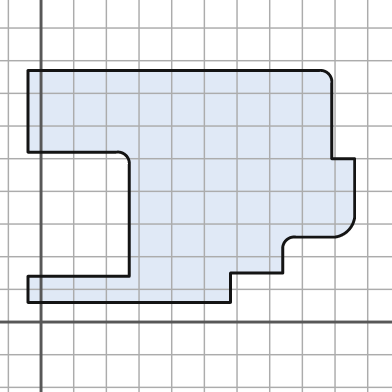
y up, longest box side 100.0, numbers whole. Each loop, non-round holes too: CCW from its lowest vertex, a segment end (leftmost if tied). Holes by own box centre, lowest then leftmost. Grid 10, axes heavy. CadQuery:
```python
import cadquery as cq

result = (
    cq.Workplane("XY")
    .moveTo(-4.0, 6.0)
    .lineTo(58.0, 6.0)
    .lineTo(58.0, 15.0)
    .lineTo(74.0, 15.0)
    .lineTo(74.0, 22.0)
    .threePointArc((75.0, 25.0), (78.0, 26.0))
    .lineTo(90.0, 26.0)
    .threePointArc((94.0, 28.0), (96.0, 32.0))
    .lineTo(96.0, 50.0)
    .lineTo(89.0, 50.0)
    .lineTo(89.0, 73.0)
    .threePointArc((88.0, 76.0), (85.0, 77.0))
    .lineTo(-4.0, 77.0)
    .lineTo(-4.0, 52.0)
    .lineTo(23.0, 52.0)
    .threePointArc((26.0, 51.0), (27.0, 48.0))
    .lineTo(27.0, 14.0)
    .lineTo(-4.0, 14.0)
    .close()
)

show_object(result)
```